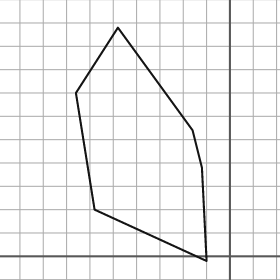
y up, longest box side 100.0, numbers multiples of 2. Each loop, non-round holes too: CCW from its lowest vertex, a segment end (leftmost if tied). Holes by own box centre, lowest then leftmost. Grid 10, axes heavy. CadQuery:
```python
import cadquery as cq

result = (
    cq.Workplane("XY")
    .moveTo(-10.0, -2.0)
    .lineTo(-12.0, 38.0)
    .lineTo(-16.0, 54.0)
    .lineTo(-48.0, 98.0)
    .lineTo(-66.0, 70.0)
    .lineTo(-58.0, 20.0)
    .close()
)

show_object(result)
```